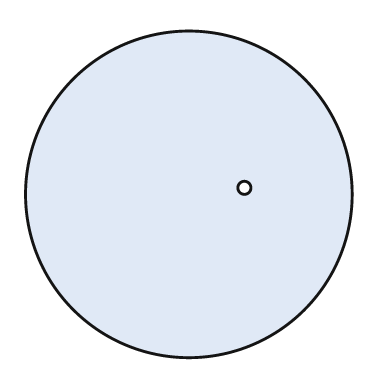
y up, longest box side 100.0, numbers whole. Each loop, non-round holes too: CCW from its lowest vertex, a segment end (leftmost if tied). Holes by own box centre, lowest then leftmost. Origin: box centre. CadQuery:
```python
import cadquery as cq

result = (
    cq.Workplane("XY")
    .moveTo(0.0, 0.0)
    .circle(50.0)
    .moveTo(17.0, 2.0)
    .circle(2.0)
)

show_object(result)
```